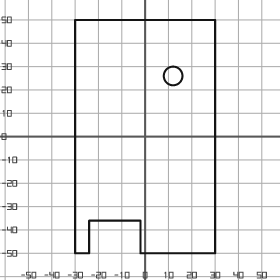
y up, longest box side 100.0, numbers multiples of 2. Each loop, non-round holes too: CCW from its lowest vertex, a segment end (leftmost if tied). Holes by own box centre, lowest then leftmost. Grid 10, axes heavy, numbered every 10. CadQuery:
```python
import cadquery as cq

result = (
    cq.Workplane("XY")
    .moveTo(-30.0, -50.0)
    .lineTo(-24.0, -50.0)
    .lineTo(-24.0, -36.0)
    .lineTo(-2.0, -36.0)
    .lineTo(-2.0, -50.0)
    .lineTo(30.0, -50.0)
    .lineTo(30.0, 50.0)
    .lineTo(-30.0, 50.0)
    .close()
    .moveTo(12.0, 26.0)
    .circle(4.0)
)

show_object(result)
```